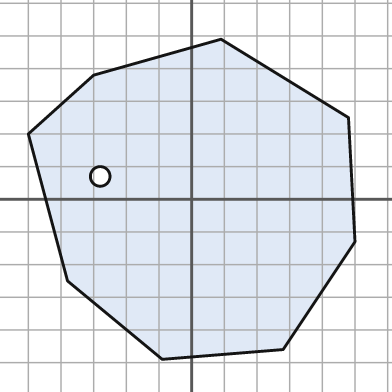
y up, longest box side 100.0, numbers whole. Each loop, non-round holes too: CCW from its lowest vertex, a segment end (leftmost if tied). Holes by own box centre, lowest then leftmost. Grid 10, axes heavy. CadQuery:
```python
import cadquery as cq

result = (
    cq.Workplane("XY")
    .moveTo(-9.0, -49.0)
    .lineTo(28.0, -46.0)
    .lineTo(50.0, -13.0)
    .lineTo(48.0, 25.0)
    .lineTo(9.0, 49.0)
    .lineTo(-30.0, 38.0)
    .lineTo(-50.0, 20.0)
    .lineTo(-38.0, -25.0)
    .close()
    .moveTo(-28.0, 7.0)
    .circle(3.0)
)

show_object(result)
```